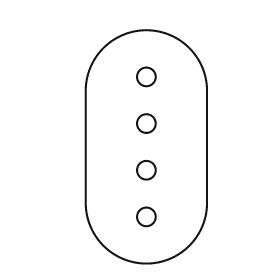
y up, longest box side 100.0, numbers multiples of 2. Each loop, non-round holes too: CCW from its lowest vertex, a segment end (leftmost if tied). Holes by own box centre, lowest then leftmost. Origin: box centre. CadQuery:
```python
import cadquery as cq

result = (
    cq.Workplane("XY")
    .moveTo(-26.0, -24.0)
    .threePointArc((0.0, -50.0), (26.0, -24.0))
    .lineTo(26.0, 24.0)
    .threePointArc((0.0, 50.0), (-26.0, 24.0))
    .close()
    .moveTo(0.0, -30.0)
    .circle(4.0)
    .moveTo(0.0, -10.0)
    .circle(4.0)
    .moveTo(0.0, 10.0)
    .circle(4.0)
    .moveTo(0.0, 30.0)
    .circle(4.0)
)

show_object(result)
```